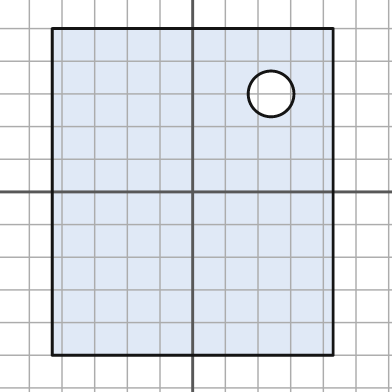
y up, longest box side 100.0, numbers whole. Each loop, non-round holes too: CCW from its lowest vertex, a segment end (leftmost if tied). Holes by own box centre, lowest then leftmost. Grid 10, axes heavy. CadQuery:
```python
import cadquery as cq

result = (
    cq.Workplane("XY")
    .moveTo(-43.0, -50.0)
    .lineTo(43.0, -50.0)
    .lineTo(43.0, 50.0)
    .lineTo(-43.0, 50.0)
    .close()
    .moveTo(24.0, 30.0)
    .circle(7.0)
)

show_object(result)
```